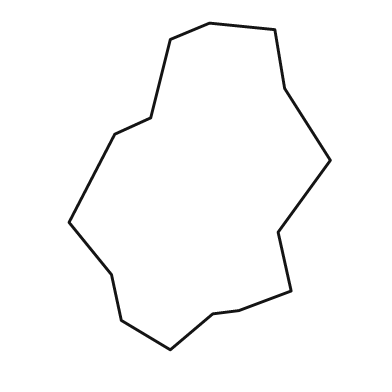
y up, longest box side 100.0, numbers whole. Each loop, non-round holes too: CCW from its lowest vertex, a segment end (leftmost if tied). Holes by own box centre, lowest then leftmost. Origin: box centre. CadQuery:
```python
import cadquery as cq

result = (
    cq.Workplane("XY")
    .moveTo(-9.0, -50.0)
    .lineTo(4.0, -39.0)
    .lineTo(12.0, -38.0)
    .lineTo(28.0, -32.0)
    .lineTo(24.0, -14.0)
    .lineTo(40.0, 8.0)
    .lineTo(26.0, 30.0)
    .lineTo(23.0, 48.0)
    .lineTo(3.0, 50.0)
    .lineTo(-9.0, 45.0)
    .lineTo(-15.0, 21.0)
    .lineTo(-26.0, 16.0)
    .lineTo(-40.0, -11.0)
    .lineTo(-27.0, -27.0)
    .lineTo(-24.0, -41.0)
    .close()
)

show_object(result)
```